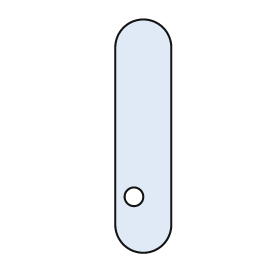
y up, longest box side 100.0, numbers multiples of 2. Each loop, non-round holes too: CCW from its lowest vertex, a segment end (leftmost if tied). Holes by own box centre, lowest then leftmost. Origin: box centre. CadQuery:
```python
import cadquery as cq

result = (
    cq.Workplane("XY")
    .moveTo(-12.0, -38.0)
    .threePointArc((0.0, -50.0), (12.0, -38.0))
    .lineTo(12.0, 38.0)
    .threePointArc((0.0, 50.0), (-12.0, 38.0))
    .close()
    .moveTo(-4.0, -26.0)
    .circle(4.0)
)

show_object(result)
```